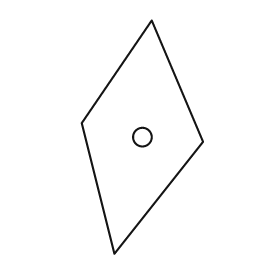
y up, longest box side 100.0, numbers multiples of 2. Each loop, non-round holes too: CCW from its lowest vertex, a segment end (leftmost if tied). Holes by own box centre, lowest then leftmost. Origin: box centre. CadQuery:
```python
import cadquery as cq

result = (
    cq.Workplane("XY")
    .moveTo(-12.0, -50.0)
    .lineTo(26.0, -2.0)
    .lineTo(4.0, 50.0)
    .lineTo(-26.0, 6.0)
    .close()
    .moveTo(0.0, 0.0)
    .circle(4.0)
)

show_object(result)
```